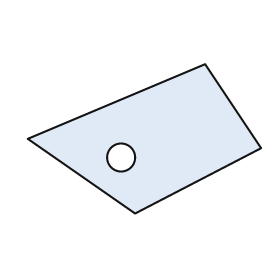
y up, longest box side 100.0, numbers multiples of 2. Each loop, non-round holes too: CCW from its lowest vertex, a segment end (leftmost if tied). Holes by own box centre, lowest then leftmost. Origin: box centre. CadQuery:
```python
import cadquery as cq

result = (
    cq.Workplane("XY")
    .moveTo(-4.0, -32.0)
    .lineTo(50.0, -4.0)
    .lineTo(26.0, 32.0)
    .lineTo(-50.0, 0.0)
    .close()
    .moveTo(-10.0, -8.0)
    .circle(6.0)
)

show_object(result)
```